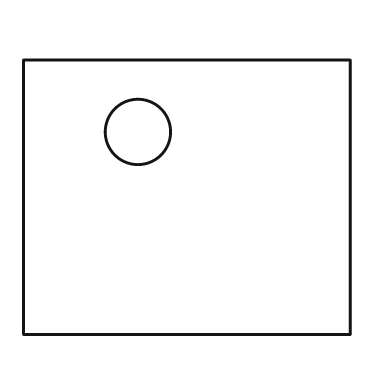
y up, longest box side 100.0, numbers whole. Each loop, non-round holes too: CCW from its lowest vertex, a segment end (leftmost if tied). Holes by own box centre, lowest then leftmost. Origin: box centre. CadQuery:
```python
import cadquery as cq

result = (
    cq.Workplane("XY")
    .moveTo(-50.0, -42.0)
    .lineTo(50.0, -42.0)
    .lineTo(50.0, 42.0)
    .lineTo(-50.0, 42.0)
    .close()
    .moveTo(-15.0, 20.0)
    .circle(10.0)
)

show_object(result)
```